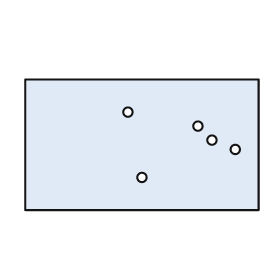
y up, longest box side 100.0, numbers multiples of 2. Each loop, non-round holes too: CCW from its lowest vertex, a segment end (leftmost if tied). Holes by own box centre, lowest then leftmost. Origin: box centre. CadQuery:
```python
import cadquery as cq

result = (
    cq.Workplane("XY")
    .moveTo(-50.0, -28.0)
    .lineTo(50.0, -28.0)
    .lineTo(50.0, 28.0)
    .lineTo(-50.0, 28.0)
    .close()
    .moveTo(0.0, -14.0)
    .circle(2.0)
    .moveTo(40.0, -2.0)
    .circle(2.0)
    .moveTo(30.0, 2.0)
    .circle(2.0)
    .moveTo(24.0, 8.0)
    .circle(2.0)
    .moveTo(-6.0, 14.0)
    .circle(2.0)
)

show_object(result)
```